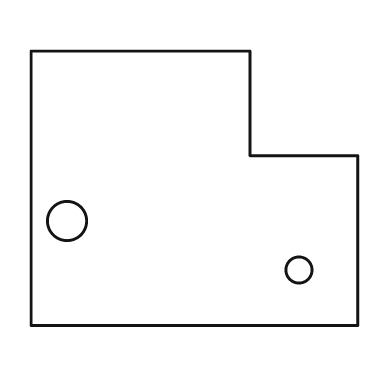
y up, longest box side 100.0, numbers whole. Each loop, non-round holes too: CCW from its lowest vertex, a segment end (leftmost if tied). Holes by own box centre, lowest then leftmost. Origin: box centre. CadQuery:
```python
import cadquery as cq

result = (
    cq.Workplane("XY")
    .moveTo(-50.0, -42.0)
    .lineTo(50.0, -42.0)
    .lineTo(50.0, 10.0)
    .lineTo(17.0, 10.0)
    .lineTo(17.0, 42.0)
    .lineTo(-50.0, 42.0)
    .close()
    .moveTo(32.0, -25.0)
    .circle(4.0)
    .moveTo(-39.0, -10.0)
    .circle(6.0)
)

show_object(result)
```